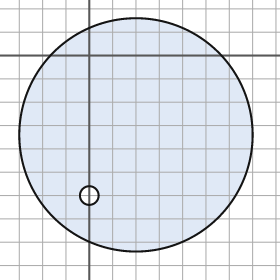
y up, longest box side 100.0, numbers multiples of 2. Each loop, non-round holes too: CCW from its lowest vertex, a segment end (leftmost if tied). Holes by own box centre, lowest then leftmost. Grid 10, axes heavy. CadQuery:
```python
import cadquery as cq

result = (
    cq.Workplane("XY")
    .moveTo(20.0, -34.0)
    .circle(50.0)
    .moveTo(0.0, -60.0)
    .circle(4.0)
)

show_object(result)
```